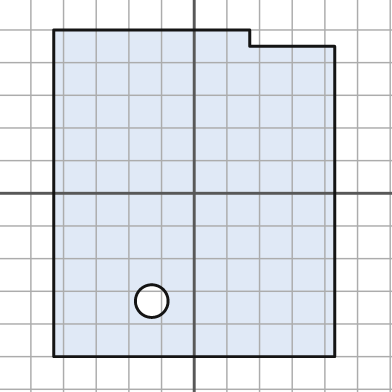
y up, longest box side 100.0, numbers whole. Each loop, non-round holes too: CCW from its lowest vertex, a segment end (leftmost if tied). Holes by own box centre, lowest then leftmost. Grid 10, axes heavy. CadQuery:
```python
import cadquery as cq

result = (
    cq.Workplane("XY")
    .moveTo(-43.0, -50.0)
    .lineTo(43.0, -50.0)
    .lineTo(43.0, 45.0)
    .lineTo(17.0, 45.0)
    .lineTo(17.0, 50.0)
    .lineTo(-43.0, 50.0)
    .close()
    .moveTo(-13.0, -33.0)
    .circle(5.0)
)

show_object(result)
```